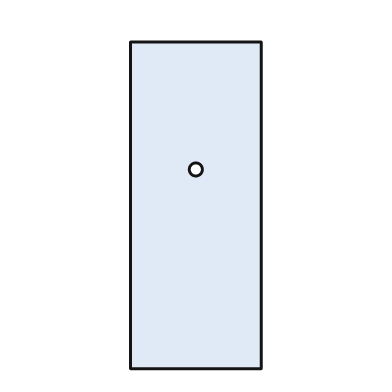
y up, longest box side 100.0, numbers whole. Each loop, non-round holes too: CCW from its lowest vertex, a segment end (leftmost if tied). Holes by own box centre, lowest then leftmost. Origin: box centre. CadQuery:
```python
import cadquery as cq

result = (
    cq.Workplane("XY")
    .moveTo(-20.0, -50.0)
    .lineTo(20.0, -50.0)
    .lineTo(20.0, 50.0)
    .lineTo(-20.0, 50.0)
    .close()
    .moveTo(0.0, 11.0)
    .circle(2.0)
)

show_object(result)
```